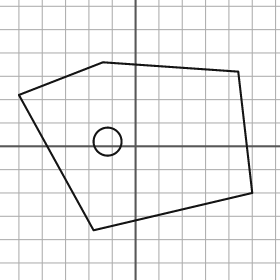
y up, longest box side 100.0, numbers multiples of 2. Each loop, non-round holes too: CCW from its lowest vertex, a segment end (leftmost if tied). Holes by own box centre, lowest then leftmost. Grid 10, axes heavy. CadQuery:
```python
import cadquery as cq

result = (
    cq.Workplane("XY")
    .moveTo(-18.0, -36.0)
    .lineTo(50.0, -20.0)
    .lineTo(44.0, 32.0)
    .lineTo(-14.0, 36.0)
    .lineTo(-50.0, 22.0)
    .close()
    .moveTo(-12.0, 2.0)
    .circle(6.0)
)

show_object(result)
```